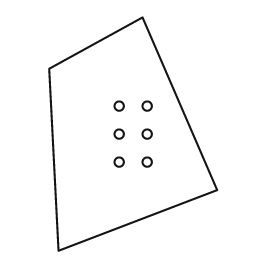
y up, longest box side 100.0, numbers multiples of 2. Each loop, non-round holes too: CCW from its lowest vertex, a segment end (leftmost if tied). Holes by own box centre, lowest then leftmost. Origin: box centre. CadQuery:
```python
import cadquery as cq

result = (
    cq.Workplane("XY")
    .moveTo(-32.0, -50.0)
    .lineTo(36.0, -24.0)
    .lineTo(4.0, 50.0)
    .lineTo(-36.0, 28.0)
    .close()
    .moveTo(-6.0, -12.0)
    .circle(2.0)
    .moveTo(6.0, -12.0)
    .circle(2.0)
    .moveTo(-6.0, 0.0)
    .circle(2.0)
    .moveTo(6.0, 0.0)
    .circle(2.0)
    .moveTo(-6.0, 12.0)
    .circle(2.0)
    .moveTo(6.0, 12.0)
    .circle(2.0)
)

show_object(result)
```